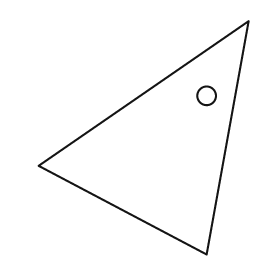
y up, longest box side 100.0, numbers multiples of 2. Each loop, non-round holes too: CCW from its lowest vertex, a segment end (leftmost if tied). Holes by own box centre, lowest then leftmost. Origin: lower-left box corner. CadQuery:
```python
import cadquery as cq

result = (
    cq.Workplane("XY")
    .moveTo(72.0, 0.0)
    .lineTo(90.0, 100.0)
    .lineTo(0.0, 38.0)
    .close()
    .moveTo(72.0, 68.0)
    .circle(4.0)
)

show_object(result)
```